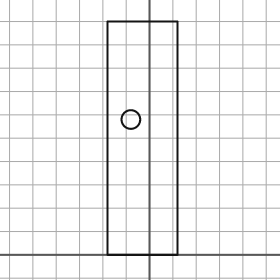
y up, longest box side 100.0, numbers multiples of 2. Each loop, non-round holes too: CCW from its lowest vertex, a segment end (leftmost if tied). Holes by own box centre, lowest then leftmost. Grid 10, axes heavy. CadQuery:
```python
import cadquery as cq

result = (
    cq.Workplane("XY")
    .moveTo(-18.0, 0.0)
    .lineTo(12.0, 0.0)
    .lineTo(12.0, 100.0)
    .lineTo(-18.0, 100.0)
    .close()
    .moveTo(-8.0, 58.0)
    .circle(4.0)
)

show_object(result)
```